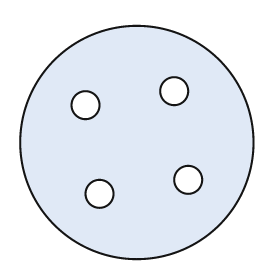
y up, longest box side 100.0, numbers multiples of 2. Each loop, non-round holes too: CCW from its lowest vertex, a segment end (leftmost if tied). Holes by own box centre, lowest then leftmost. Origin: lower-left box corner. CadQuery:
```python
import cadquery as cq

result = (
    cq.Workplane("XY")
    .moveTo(50.0, 50.0)
    .circle(50.0)
    .moveTo(34.0, 28.0)
    .circle(6.0)
    .moveTo(72.0, 34.0)
    .circle(6.0)
    .moveTo(28.0, 66.0)
    .circle(6.0)
    .moveTo(66.0, 72.0)
    .circle(6.0)
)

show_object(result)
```